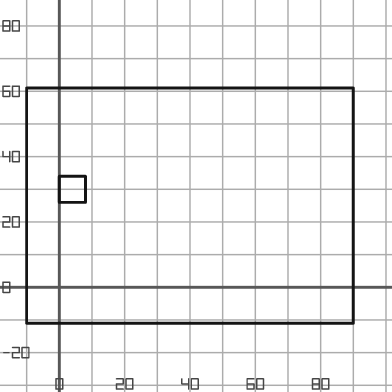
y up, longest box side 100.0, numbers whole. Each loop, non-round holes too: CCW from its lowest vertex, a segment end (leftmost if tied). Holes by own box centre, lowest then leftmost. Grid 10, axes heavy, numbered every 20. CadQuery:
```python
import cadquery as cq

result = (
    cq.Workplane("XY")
    .moveTo(-10.0, -11.0)
    .lineTo(90.0, -11.0)
    .lineTo(90.0, 61.0)
    .lineTo(-10.0, 61.0)
    .close()
    .moveTo(0.0, 26.0)
    .lineTo(8.0, 26.0)
    .lineTo(8.0, 34.0)
    .lineTo(0.0, 34.0)
    .close()
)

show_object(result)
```